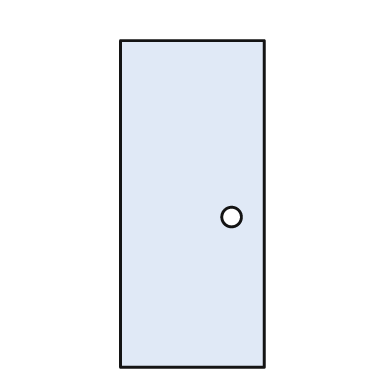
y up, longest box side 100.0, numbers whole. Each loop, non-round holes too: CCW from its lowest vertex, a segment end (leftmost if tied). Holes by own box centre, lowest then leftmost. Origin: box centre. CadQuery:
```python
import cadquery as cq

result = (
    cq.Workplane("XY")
    .moveTo(-22.0, -50.0)
    .lineTo(22.0, -50.0)
    .lineTo(22.0, 50.0)
    .lineTo(-22.0, 50.0)
    .close()
    .moveTo(12.0, -4.0)
    .circle(3.0)
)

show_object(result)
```